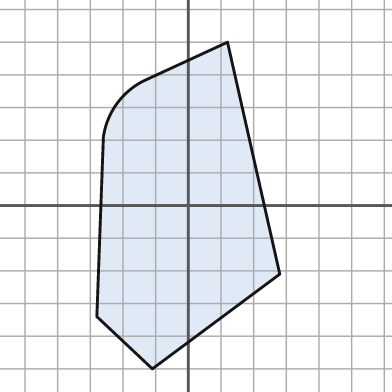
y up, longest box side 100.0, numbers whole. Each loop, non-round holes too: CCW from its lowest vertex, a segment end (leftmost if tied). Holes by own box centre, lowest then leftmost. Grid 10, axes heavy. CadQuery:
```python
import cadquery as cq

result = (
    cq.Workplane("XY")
    .moveTo(-11.0, -50.0)
    .lineTo(28.0, -21.0)
    .lineTo(12.0, 50.0)
    .lineTo(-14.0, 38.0)
    .threePointArc((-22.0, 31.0), (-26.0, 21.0))
    .lineTo(-28.0, -34.0)
    .close()
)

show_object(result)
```